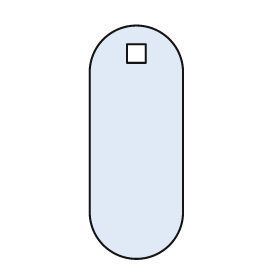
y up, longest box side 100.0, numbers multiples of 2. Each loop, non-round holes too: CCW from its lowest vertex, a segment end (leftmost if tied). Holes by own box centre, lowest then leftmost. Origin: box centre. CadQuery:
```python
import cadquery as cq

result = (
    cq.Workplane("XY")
    .moveTo(-20.0, -30.0)
    .threePointArc((0.0, -50.0), (20.0, -30.0))
    .lineTo(20.0, 30.0)
    .threePointArc((0.0, 50.0), (-20.0, 30.0))
    .close()
    .moveTo(-4.0, 34.0)
    .lineTo(4.0, 34.0)
    .lineTo(4.0, 42.0)
    .lineTo(-4.0, 42.0)
    .close()
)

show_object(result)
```